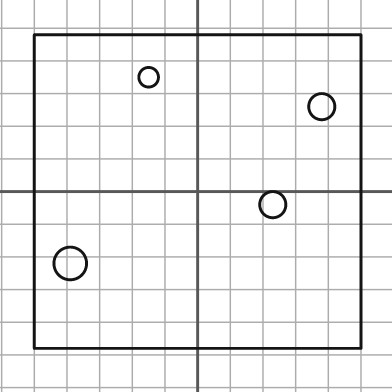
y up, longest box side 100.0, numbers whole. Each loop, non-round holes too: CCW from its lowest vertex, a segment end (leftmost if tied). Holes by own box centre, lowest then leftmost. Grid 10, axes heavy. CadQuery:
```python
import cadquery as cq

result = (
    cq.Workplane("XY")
    .moveTo(-50.0, -48.0)
    .lineTo(50.0, -48.0)
    .lineTo(50.0, 48.0)
    .lineTo(-50.0, 48.0)
    .close()
    .moveTo(-39.0, -22.0)
    .circle(5.0)
    .moveTo(23.0, -4.0)
    .circle(4.0)
    .moveTo(38.0, 26.0)
    .circle(4.0)
    .moveTo(-15.0, 35.0)
    .circle(3.0)
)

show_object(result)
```